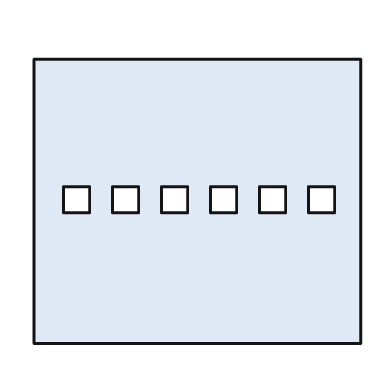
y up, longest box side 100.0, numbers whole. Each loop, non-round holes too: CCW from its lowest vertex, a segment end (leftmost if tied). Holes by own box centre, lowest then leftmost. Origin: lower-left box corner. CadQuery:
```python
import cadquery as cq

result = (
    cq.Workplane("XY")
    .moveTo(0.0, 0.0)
    .lineTo(100.0, 0.0)
    .lineTo(100.0, 87.0)
    .lineTo(0.0, 87.0)
    .close()
    .moveTo(9.0, 40.0)
    .lineTo(17.0, 40.0)
    .lineTo(17.0, 48.0)
    .lineTo(9.0, 48.0)
    .close()
    .moveTo(24.0, 40.0)
    .lineTo(32.0, 40.0)
    .lineTo(32.0, 48.0)
    .lineTo(24.0, 48.0)
    .close()
    .moveTo(39.0, 40.0)
    .lineTo(47.0, 40.0)
    .lineTo(47.0, 48.0)
    .lineTo(39.0, 48.0)
    .close()
    .moveTo(54.0, 40.0)
    .lineTo(62.0, 40.0)
    .lineTo(62.0, 48.0)
    .lineTo(54.0, 48.0)
    .close()
    .moveTo(69.0, 40.0)
    .lineTo(77.0, 40.0)
    .lineTo(77.0, 48.0)
    .lineTo(69.0, 48.0)
    .close()
    .moveTo(84.0, 40.0)
    .lineTo(92.0, 40.0)
    .lineTo(92.0, 48.0)
    .lineTo(84.0, 48.0)
    .close()
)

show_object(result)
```